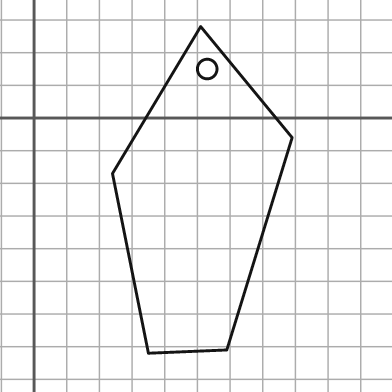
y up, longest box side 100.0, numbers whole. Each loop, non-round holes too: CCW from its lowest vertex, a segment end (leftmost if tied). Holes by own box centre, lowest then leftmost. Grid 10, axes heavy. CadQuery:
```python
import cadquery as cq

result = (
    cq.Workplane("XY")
    .moveTo(35.0, -72.0)
    .lineTo(59.0, -71.0)
    .lineTo(79.0, -6.0)
    .lineTo(51.0, 28.0)
    .lineTo(24.0, -17.0)
    .close()
    .moveTo(53.0, 15.0)
    .circle(3.0)
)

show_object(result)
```